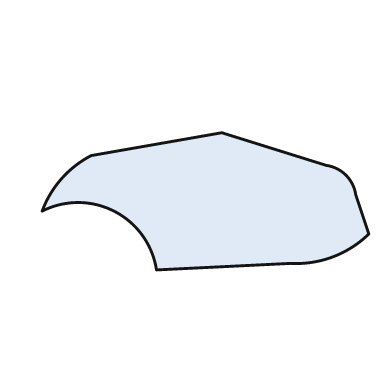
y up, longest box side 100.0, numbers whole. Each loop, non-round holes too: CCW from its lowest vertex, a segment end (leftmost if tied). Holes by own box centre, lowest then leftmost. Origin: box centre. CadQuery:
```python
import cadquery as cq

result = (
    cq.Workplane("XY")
    .moveTo(-15.0, -21.0)
    .lineTo(26.0, -19.0)
    .threePointArc((39.0, -17.0), (50.0, -10.0))
    .lineTo(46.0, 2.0)
    .threePointArc((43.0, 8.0), (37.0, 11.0))
    .lineTo(5.0, 21.0)
    .lineTo(-35.0, 14.0)
    .threePointArc((-44.0, 7.0), (-50.0, -3.0))
    .threePointArc((-28.0, -3.0), (-15.0, -21.0))
    .close()
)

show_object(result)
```